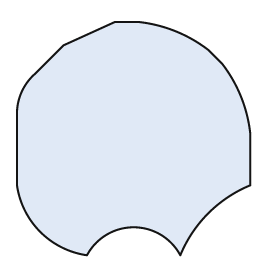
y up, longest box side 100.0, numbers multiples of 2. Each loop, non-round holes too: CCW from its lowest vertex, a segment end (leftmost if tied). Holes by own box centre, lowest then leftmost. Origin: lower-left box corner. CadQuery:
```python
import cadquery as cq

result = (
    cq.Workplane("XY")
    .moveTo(30.0, 0.0)
    .threePointArc((50.0, 12.0), (70.0, 0.0))
    .threePointArc((82.0, 18.0), (100.0, 30.0))
    .lineTo(100.0, 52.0)
    .threePointArc((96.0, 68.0), (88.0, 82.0))
    .lineTo(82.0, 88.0)
    .threePointArc((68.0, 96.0), (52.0, 100.0))
    .lineTo(42.0, 100.0)
    .lineTo(20.0, 90.0)
    .lineTo(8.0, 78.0)
    .threePointArc((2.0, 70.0), (0.0, 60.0))
    .lineTo(0.0, 30.0)
    .threePointArc((10.0, 10.0), (30.0, 0.0))
    .close()
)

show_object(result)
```